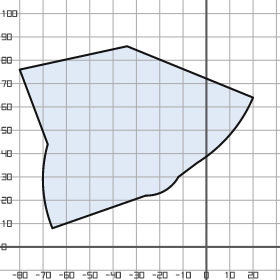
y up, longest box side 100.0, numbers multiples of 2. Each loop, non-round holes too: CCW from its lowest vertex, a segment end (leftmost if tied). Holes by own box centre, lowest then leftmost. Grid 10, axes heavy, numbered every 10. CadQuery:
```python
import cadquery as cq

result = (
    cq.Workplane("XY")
    .moveTo(-66.0, 8.0)
    .lineTo(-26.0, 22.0)
    .threePointArc((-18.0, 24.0), (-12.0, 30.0))
    .lineTo(-4.0, 36.0)
    .threePointArc((10.0, 48.0), (20.0, 64.0))
    .lineTo(-34.0, 86.0)
    .lineTo(-80.0, 76.0)
    .lineTo(-68.0, 44.0)
    .threePointArc((-70.0, 26.0), (-66.0, 8.0))
    .close()
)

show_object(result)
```